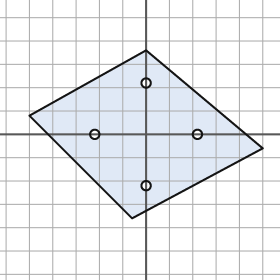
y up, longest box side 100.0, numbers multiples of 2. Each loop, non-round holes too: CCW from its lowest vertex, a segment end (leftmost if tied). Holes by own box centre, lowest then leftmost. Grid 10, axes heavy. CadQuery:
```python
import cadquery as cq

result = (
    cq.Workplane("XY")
    .moveTo(-6.0, -36.0)
    .lineTo(50.0, -6.0)
    .lineTo(0.0, 36.0)
    .lineTo(-50.0, 8.0)
    .close()
    .moveTo(0.0, -22.0)
    .circle(2.0)
    .moveTo(-22.0, 0.0)
    .circle(2.0)
    .moveTo(22.0, 0.0)
    .circle(2.0)
    .moveTo(0.0, 22.0)
    .circle(2.0)
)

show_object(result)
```